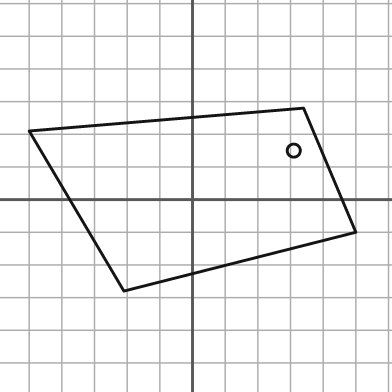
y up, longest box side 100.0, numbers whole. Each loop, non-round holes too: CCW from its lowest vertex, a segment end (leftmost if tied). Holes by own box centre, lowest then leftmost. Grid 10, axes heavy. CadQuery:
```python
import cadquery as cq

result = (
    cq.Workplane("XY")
    .moveTo(-21.0, -28.0)
    .lineTo(50.0, -10.0)
    .lineTo(34.0, 28.0)
    .lineTo(-50.0, 21.0)
    .close()
    .moveTo(31.0, 15.0)
    .circle(2.0)
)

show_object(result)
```